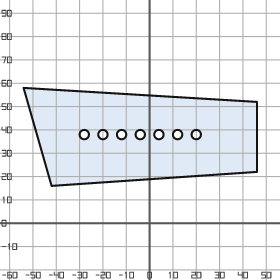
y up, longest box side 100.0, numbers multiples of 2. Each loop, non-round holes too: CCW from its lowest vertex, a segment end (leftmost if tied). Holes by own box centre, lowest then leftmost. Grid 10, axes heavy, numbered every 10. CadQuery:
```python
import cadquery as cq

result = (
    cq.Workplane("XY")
    .moveTo(-42.0, 16.0)
    .lineTo(46.0, 22.0)
    .lineTo(46.0, 52.0)
    .lineTo(-54.0, 58.0)
    .close()
    .moveTo(-28.0, 38.0)
    .circle(2.0)
    .moveTo(-20.0, 38.0)
    .circle(2.0)
    .moveTo(-12.0, 38.0)
    .circle(2.0)
    .moveTo(-4.0, 38.0)
    .circle(2.0)
    .moveTo(4.0, 38.0)
    .circle(2.0)
    .moveTo(12.0, 38.0)
    .circle(2.0)
    .moveTo(20.0, 38.0)
    .circle(2.0)
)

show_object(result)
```